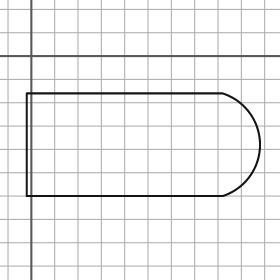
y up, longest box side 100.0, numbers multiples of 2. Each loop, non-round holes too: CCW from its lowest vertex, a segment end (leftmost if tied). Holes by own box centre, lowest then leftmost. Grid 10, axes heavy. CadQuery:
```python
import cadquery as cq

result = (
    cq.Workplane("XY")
    .moveTo(-2.0, -60.0)
    .lineTo(82.0, -60.0)
    .threePointArc((98.0, -38.0), (82.0, -16.0))
    .lineTo(-2.0, -16.0)
    .close()
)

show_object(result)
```